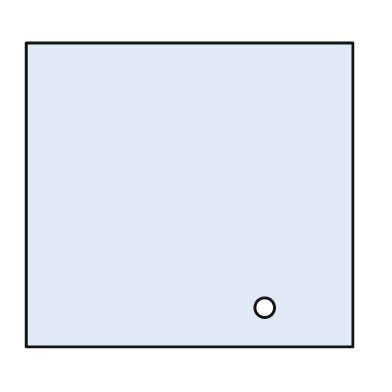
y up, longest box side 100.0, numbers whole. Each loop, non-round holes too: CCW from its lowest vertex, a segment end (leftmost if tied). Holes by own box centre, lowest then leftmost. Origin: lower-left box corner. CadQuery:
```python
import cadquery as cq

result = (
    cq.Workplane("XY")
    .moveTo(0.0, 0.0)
    .lineTo(100.0, 0.0)
    .lineTo(100.0, 93.0)
    .lineTo(0.0, 93.0)
    .close()
    .moveTo(73.0, 12.0)
    .circle(3.0)
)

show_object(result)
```